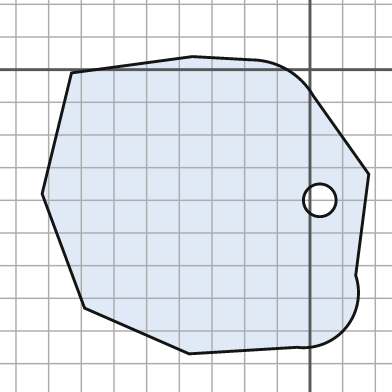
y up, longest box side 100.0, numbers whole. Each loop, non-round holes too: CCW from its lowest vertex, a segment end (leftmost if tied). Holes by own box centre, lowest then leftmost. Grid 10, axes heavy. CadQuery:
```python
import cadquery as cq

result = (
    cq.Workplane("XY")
    .moveTo(-37.0, -87.0)
    .lineTo(-4.0, -85.0)
    .threePointArc((11.0, -79.0), (14.0, -63.0))
    .lineTo(18.0, -32.0)
    .lineTo(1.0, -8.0)
    .threePointArc((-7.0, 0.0), (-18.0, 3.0))
    .lineTo(-36.0, 4.0)
    .lineTo(-73.0, -1.0)
    .lineTo(-82.0, -38.0)
    .lineTo(-69.0, -73.0)
    .close()
    .moveTo(3.0, -40.0)
    .circle(5.0)
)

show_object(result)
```